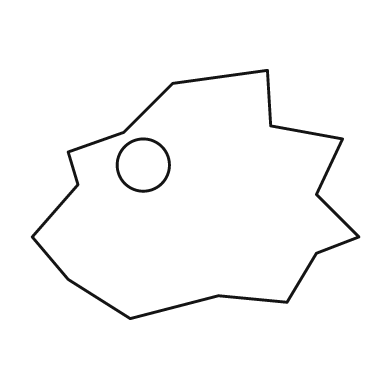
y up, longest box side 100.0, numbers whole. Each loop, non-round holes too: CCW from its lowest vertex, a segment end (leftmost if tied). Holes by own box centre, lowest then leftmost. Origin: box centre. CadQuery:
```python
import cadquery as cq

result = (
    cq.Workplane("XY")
    .moveTo(-20.0, -38.0)
    .lineTo(7.0, -31.0)
    .lineTo(28.0, -33.0)
    .lineTo(37.0, -18.0)
    .lineTo(50.0, -13.0)
    .lineTo(37.0, 0.0)
    .lineTo(45.0, 17.0)
    .lineTo(23.0, 21.0)
    .lineTo(22.0, 38.0)
    .lineTo(-7.0, 34.0)
    .lineTo(-22.0, 19.0)
    .lineTo(-39.0, 13.0)
    .lineTo(-36.0, 3.0)
    .lineTo(-50.0, -13.0)
    .lineTo(-39.0, -26.0)
    .close()
    .moveTo(-16.0, 9.0)
    .circle(8.0)
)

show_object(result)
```